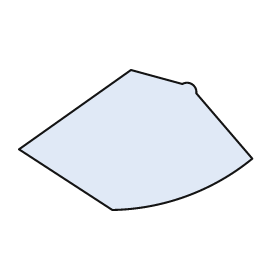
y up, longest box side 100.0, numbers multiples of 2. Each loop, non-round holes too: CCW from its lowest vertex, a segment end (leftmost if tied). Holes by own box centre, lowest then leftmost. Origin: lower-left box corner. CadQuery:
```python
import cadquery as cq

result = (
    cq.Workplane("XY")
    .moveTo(40.0, 0.0)
    .threePointArc((72.0, 6.0), (100.0, 22.0))
    .lineTo(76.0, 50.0)
    .threePointArc((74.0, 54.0), (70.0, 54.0))
    .lineTo(48.0, 60.0)
    .lineTo(0.0, 26.0)
    .close()
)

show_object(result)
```